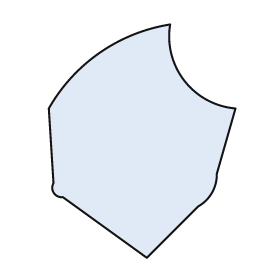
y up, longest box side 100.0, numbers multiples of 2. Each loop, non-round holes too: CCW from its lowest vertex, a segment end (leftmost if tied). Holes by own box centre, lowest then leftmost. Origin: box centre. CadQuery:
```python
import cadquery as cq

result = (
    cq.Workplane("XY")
    .moveTo(2.0, -50.0)
    .lineTo(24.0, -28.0)
    .threePointArc((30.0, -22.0), (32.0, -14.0))
    .lineTo(40.0, 14.0)
    .threePointArc((18.0, 26.0), (12.0, 50.0))
    .threePointArc((-18.0, 38.0), (-40.0, 14.0))
    .lineTo(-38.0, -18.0)
    .threePointArc((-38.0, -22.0), (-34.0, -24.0))
    .close()
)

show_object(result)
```